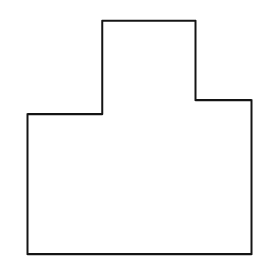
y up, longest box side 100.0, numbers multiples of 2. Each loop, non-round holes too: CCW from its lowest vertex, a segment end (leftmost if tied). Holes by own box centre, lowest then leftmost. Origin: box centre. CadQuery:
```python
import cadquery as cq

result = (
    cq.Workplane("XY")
    .moveTo(-48.0, -50.0)
    .lineTo(48.0, -50.0)
    .lineTo(48.0, 16.0)
    .lineTo(24.0, 16.0)
    .lineTo(24.0, 50.0)
    .lineTo(-16.0, 50.0)
    .lineTo(-16.0, 10.0)
    .lineTo(-48.0, 10.0)
    .close()
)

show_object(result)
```